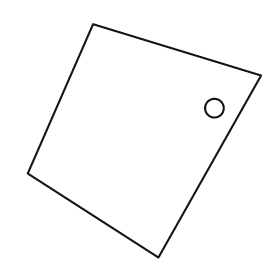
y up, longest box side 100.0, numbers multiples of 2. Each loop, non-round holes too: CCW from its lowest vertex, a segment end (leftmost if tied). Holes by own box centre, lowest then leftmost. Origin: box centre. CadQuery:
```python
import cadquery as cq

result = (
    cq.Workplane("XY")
    .moveTo(6.0, -50.0)
    .lineTo(50.0, 28.0)
    .lineTo(-22.0, 50.0)
    .lineTo(-50.0, -14.0)
    .close()
    .moveTo(30.0, 14.0)
    .circle(4.0)
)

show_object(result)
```